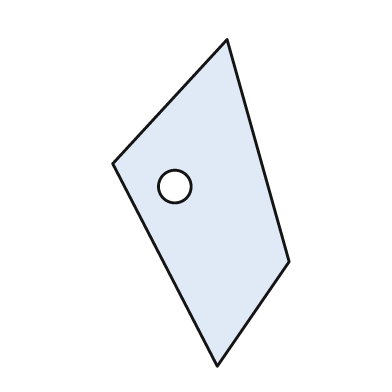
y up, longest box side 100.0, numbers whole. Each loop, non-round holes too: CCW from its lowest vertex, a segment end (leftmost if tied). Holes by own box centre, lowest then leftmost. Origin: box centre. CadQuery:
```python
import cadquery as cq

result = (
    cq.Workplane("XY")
    .moveTo(5.0, -50.0)
    .lineTo(27.0, -18.0)
    .lineTo(8.0, 50.0)
    .lineTo(-27.0, 12.0)
    .close()
    .moveTo(-8.0, 5.0)
    .circle(5.0)
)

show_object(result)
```